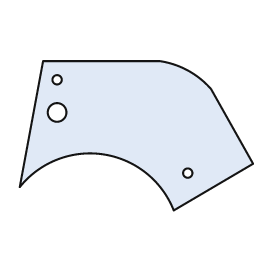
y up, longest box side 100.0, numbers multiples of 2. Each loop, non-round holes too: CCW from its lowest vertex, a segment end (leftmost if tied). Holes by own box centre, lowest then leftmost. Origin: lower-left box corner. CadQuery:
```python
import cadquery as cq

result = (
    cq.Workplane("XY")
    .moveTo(66.0, 0.0)
    .lineTo(100.0, 20.0)
    .lineTo(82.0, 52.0)
    .threePointArc((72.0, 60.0), (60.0, 64.0))
    .lineTo(10.0, 64.0)
    .lineTo(0.0, 10.0)
    .threePointArc((36.0, 24.0), (66.0, 0.0))
    .close()
    .moveTo(72.0, 16.0)
    .circle(2.0)
    .moveTo(16.0, 42.0)
    .circle(4.0)
    .moveTo(16.0, 56.0)
    .circle(2.0)
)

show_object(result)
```